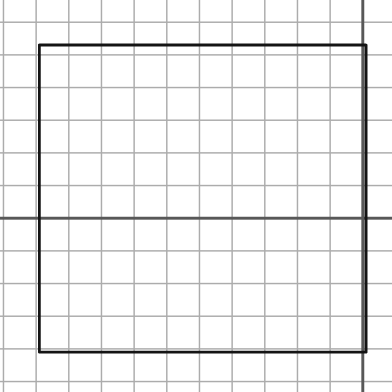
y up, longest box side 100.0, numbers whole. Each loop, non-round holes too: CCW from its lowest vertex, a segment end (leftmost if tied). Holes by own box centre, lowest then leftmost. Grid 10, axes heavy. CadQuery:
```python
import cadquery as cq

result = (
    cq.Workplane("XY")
    .moveTo(-99.0, -41.0)
    .lineTo(1.0, -41.0)
    .lineTo(1.0, 53.0)
    .lineTo(-99.0, 53.0)
    .close()
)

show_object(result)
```